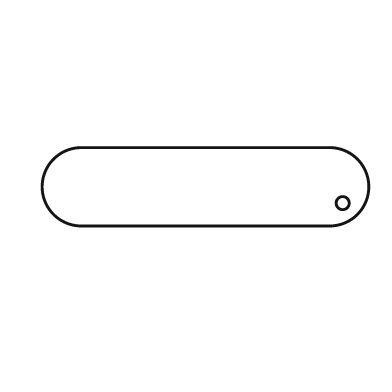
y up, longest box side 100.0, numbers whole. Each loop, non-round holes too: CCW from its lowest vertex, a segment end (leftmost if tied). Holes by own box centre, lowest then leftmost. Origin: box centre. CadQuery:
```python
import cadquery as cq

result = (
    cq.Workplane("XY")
    .moveTo(-38.0, -12.0)
    .lineTo(38.0, -12.0)
    .threePointArc((50.0, 0.0), (38.0, 12.0))
    .lineTo(-38.0, 12.0)
    .threePointArc((-50.0, 0.0), (-38.0, -12.0))
    .close()
    .moveTo(42.0, -5.0)
    .circle(2.0)
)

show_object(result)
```